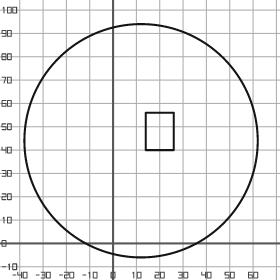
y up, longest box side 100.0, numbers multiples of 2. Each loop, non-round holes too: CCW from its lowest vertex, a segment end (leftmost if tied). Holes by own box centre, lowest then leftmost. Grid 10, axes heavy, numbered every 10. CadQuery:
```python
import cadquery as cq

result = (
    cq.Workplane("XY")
    .moveTo(12.0, 44.0)
    .circle(50.0)
    .moveTo(14.0, 40.0)
    .lineTo(26.0, 40.0)
    .lineTo(26.0, 56.0)
    .lineTo(14.0, 56.0)
    .close()
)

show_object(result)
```